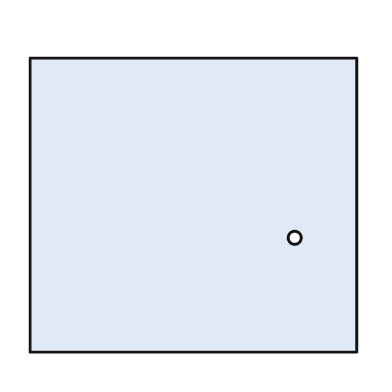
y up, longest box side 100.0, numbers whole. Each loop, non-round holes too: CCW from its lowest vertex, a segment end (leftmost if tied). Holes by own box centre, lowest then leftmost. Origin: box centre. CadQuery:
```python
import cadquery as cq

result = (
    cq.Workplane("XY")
    .moveTo(-50.0, -45.0)
    .lineTo(50.0, -45.0)
    .lineTo(50.0, 45.0)
    .lineTo(-50.0, 45.0)
    .close()
    .moveTo(31.0, -10.0)
    .circle(2.0)
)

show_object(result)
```